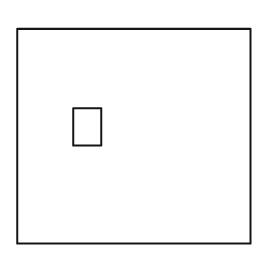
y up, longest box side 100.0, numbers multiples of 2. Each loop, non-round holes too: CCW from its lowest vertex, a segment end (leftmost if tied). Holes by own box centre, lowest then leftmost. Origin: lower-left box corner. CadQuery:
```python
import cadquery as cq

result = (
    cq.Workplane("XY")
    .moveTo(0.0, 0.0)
    .lineTo(100.0, 0.0)
    .lineTo(100.0, 92.0)
    .lineTo(0.0, 92.0)
    .close()
    .moveTo(24.0, 42.0)
    .lineTo(36.0, 42.0)
    .lineTo(36.0, 58.0)
    .lineTo(24.0, 58.0)
    .close()
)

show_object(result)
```